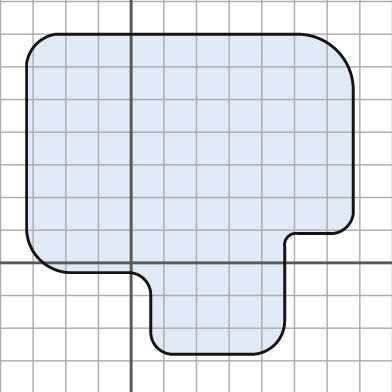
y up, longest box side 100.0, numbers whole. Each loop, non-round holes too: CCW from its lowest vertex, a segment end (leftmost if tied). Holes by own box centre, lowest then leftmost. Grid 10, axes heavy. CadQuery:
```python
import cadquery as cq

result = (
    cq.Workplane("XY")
    .moveTo(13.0, -28.0)
    .lineTo(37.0, -28.0)
    .threePointArc((44.0, -25.0), (47.0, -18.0))
    .lineTo(47.0, 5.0)
    .threePointArc((48.0, 8.0), (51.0, 9.0))
    .lineTo(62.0, 9.0)
    .threePointArc((66.0, 11.0), (68.0, 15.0))
    .lineTo(68.0, 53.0)
    .threePointArc((63.0, 65.0), (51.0, 70.0))
    .lineTo(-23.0, 70.0)
    .threePointArc((-29.0, 67.0), (-32.0, 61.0))
    .lineTo(-32.0, 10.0)
    .threePointArc((-28.0, 1.0), (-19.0, -3.0))
    .lineTo(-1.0, -3.0)
    .threePointArc((4.0, -5.0), (6.0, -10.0))
    .lineTo(6.0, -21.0)
    .threePointArc((8.0, -26.0), (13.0, -28.0))
    .close()
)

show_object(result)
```